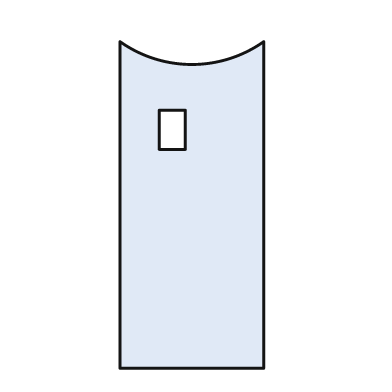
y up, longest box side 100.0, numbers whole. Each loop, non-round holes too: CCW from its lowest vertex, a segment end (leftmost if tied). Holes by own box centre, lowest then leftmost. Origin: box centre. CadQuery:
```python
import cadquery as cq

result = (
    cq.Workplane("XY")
    .moveTo(-22.0, -50.0)
    .lineTo(22.0, -50.0)
    .lineTo(22.0, 50.0)
    .threePointArc((0.0, 43.0), (-22.0, 50.0))
    .close()
    .moveTo(-10.0, 17.0)
    .lineTo(-2.0, 17.0)
    .lineTo(-2.0, 29.0)
    .lineTo(-10.0, 29.0)
    .close()
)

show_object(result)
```